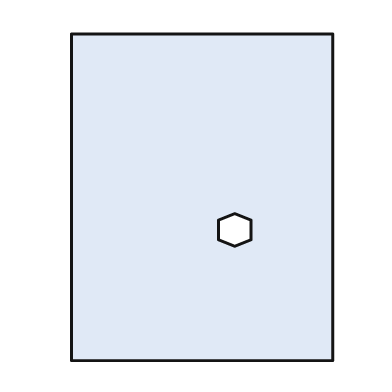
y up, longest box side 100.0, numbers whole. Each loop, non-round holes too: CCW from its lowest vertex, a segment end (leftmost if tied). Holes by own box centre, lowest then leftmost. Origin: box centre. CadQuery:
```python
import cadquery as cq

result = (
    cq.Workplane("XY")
    .moveTo(-40.0, -50.0)
    .lineTo(40.0, -50.0)
    .lineTo(40.0, 50.0)
    .lineTo(-40.0, 50.0)
    .close()
    .moveTo(10.0, -15.0)
    .lineTo(15.0, -13.0)
    .lineTo(15.0, -7.0)
    .lineTo(10.0, -5.0)
    .lineTo(5.0, -7.0)
    .lineTo(5.0, -13.0)
    .close()
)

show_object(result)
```